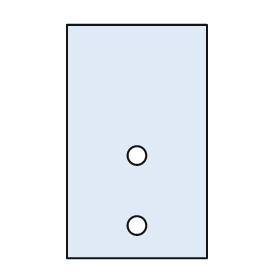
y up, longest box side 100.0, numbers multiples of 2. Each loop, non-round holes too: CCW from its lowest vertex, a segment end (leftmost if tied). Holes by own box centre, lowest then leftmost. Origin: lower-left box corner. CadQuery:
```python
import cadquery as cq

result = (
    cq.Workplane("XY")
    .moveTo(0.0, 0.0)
    .lineTo(60.0, 0.0)
    .lineTo(60.0, 100.0)
    .lineTo(0.0, 100.0)
    .close()
    .moveTo(30.0, 14.0)
    .circle(4.0)
    .moveTo(30.0, 44.0)
    .circle(4.0)
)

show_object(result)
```